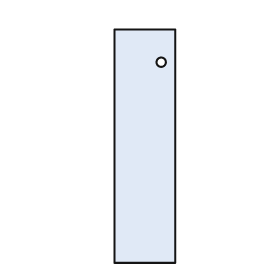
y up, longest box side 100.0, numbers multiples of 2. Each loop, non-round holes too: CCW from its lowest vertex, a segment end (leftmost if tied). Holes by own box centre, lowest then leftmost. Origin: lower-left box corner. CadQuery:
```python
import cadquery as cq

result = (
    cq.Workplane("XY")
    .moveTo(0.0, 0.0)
    .lineTo(26.0, 0.0)
    .lineTo(26.0, 100.0)
    .lineTo(0.0, 100.0)
    .close()
    .moveTo(20.0, 86.0)
    .circle(2.0)
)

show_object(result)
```